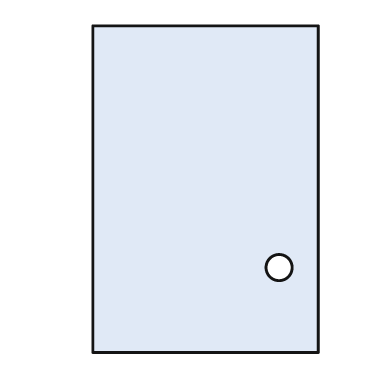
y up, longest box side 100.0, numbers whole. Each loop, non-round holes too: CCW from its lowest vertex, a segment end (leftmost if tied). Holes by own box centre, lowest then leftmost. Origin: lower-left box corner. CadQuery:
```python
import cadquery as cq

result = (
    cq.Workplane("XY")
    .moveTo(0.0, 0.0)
    .lineTo(69.0, 0.0)
    .lineTo(69.0, 100.0)
    .lineTo(0.0, 100.0)
    .close()
    .moveTo(57.0, 26.0)
    .circle(4.0)
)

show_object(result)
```